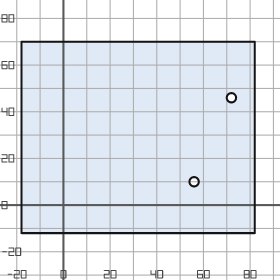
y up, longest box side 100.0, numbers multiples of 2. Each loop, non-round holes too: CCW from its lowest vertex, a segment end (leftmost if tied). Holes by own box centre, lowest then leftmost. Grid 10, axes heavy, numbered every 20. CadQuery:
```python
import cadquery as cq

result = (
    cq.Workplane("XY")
    .moveTo(-18.0, -12.0)
    .lineTo(82.0, -12.0)
    .lineTo(82.0, 70.0)
    .lineTo(-18.0, 70.0)
    .close()
    .moveTo(56.0, 10.0)
    .circle(2.0)
    .moveTo(72.0, 46.0)
    .circle(2.0)
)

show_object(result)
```